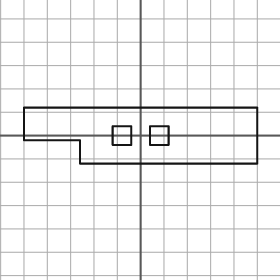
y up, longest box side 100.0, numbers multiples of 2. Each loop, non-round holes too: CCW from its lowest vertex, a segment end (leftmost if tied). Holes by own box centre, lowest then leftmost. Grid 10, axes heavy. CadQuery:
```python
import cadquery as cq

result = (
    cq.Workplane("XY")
    .moveTo(-26.0, -12.0)
    .lineTo(50.0, -12.0)
    .lineTo(50.0, 12.0)
    .lineTo(-50.0, 12.0)
    .lineTo(-50.0, -2.0)
    .lineTo(-26.0, -2.0)
    .close()
    .moveTo(-12.0, -4.0)
    .lineTo(-4.0, -4.0)
    .lineTo(-4.0, 4.0)
    .lineTo(-12.0, 4.0)
    .close()
    .moveTo(4.0, -4.0)
    .lineTo(12.0, -4.0)
    .lineTo(12.0, 4.0)
    .lineTo(4.0, 4.0)
    .close()
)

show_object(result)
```